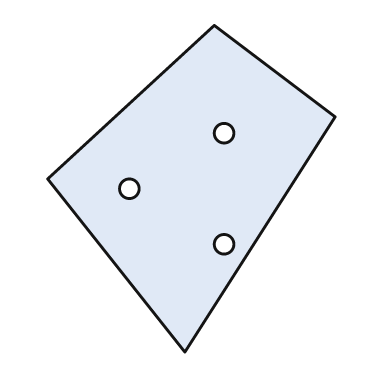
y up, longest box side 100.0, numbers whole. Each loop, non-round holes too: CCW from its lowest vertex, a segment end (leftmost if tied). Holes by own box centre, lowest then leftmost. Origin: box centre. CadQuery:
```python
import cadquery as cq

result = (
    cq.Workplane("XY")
    .moveTo(-2.0, -50.0)
    .lineTo(44.0, 22.0)
    .lineTo(7.0, 50.0)
    .lineTo(-44.0, 3.0)
    .close()
    .moveTo(10.0, -17.0)
    .circle(3.0)
    .moveTo(-19.0, 0.0)
    .circle(3.0)
    .moveTo(10.0, 17.0)
    .circle(3.0)
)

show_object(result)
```